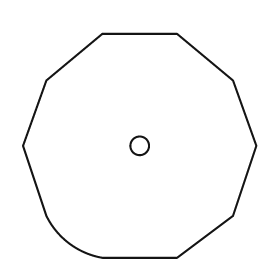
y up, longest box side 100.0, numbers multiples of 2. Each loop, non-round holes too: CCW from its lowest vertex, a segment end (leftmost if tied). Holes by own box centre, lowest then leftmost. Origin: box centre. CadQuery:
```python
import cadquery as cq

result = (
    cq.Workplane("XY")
    .moveTo(-16.0, -48.0)
    .lineTo(16.0, -48.0)
    .lineTo(40.0, -30.0)
    .lineTo(50.0, 0.0)
    .lineTo(40.0, 28.0)
    .lineTo(16.0, 48.0)
    .lineTo(-16.0, 48.0)
    .lineTo(-40.0, 28.0)
    .lineTo(-50.0, 0.0)
    .lineTo(-40.0, -30.0)
    .threePointArc((-30.0, -42.0), (-16.0, -48.0))
    .close()
    .moveTo(0.0, 0.0)
    .circle(4.0)
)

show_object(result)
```